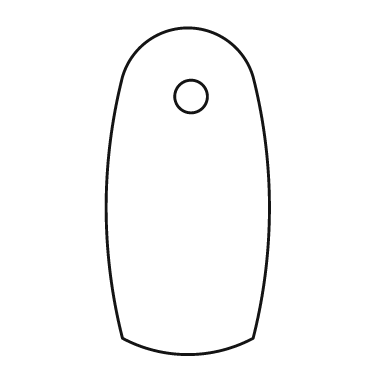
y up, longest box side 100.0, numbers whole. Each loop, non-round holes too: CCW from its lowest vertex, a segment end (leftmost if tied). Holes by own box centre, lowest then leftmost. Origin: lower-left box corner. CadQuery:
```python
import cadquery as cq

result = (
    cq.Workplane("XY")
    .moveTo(5.0, 5.0)
    .threePointArc((25.0, 0.0), (45.0, 5.0))
    .threePointArc((50.0, 45.0), (45.0, 85.0))
    .threePointArc((25.0, 100.0), (5.0, 85.0))
    .threePointArc((0.0, 45.0), (5.0, 5.0))
    .close()
    .moveTo(26.0, 79.0)
    .circle(5.0)
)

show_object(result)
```